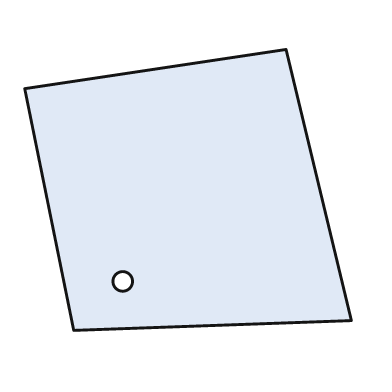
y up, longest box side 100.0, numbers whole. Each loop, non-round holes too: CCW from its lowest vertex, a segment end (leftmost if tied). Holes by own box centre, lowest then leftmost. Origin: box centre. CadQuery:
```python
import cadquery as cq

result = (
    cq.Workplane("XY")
    .moveTo(-35.0, -43.0)
    .lineTo(50.0, -40.0)
    .lineTo(30.0, 43.0)
    .lineTo(-50.0, 31.0)
    .close()
    .moveTo(-20.0, -28.0)
    .circle(3.0)
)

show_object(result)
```